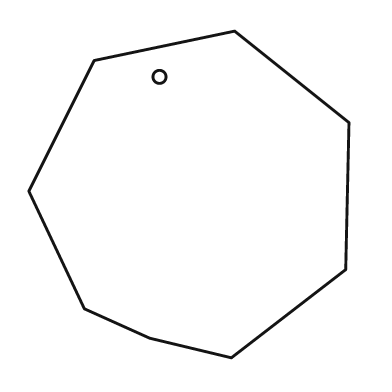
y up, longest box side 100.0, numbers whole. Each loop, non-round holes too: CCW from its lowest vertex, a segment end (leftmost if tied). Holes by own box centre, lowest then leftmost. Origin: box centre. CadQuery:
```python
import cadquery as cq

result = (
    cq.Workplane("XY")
    .moveTo(13.0, -50.0)
    .lineTo(48.0, -23.0)
    .lineTo(49.0, 22.0)
    .lineTo(14.0, 50.0)
    .lineTo(-29.0, 41.0)
    .lineTo(-49.0, 1.0)
    .lineTo(-32.0, -35.0)
    .lineTo(-12.0, -44.0)
    .close()
    .moveTo(-9.0, 36.0)
    .circle(2.0)
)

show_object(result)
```